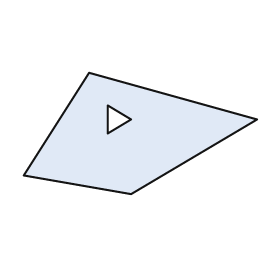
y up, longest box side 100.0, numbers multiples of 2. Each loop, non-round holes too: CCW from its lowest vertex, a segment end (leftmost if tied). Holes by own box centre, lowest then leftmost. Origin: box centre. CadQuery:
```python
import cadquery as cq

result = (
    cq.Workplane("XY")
    .moveTo(-4.0, -26.0)
    .lineTo(50.0, 6.0)
    .lineTo(-22.0, 26.0)
    .lineTo(-50.0, -18.0)
    .close()
    .moveTo(-14.0, 0.0)
    .lineTo(-4.0, 6.0)
    .lineTo(-14.0, 12.0)
    .close()
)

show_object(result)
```